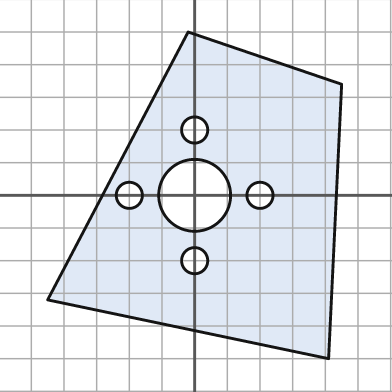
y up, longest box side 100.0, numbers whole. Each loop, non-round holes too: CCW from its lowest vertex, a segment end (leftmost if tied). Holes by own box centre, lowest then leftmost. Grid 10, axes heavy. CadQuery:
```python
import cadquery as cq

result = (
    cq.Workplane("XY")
    .moveTo(41.0, -50.0)
    .lineTo(45.0, 34.0)
    .lineTo(-2.0, 50.0)
    .lineTo(-45.0, -32.0)
    .close()
    .moveTo(0.0, -20.0)
    .circle(4.0)
    .moveTo(-20.0, 0.0)
    .circle(4.0)
    .moveTo(0.0, 0.0)
    .circle(11.0)
    .moveTo(20.0, 0.0)
    .circle(4.0)
    .moveTo(0.0, 20.0)
    .circle(4.0)
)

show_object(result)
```